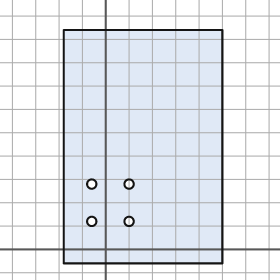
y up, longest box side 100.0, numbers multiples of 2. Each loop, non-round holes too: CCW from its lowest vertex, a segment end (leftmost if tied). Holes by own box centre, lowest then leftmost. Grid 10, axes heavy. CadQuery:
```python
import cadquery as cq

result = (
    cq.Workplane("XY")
    .moveTo(-18.0, -6.0)
    .lineTo(50.0, -6.0)
    .lineTo(50.0, 94.0)
    .lineTo(-18.0, 94.0)
    .close()
    .moveTo(-6.0, 12.0)
    .circle(2.0)
    .moveTo(10.0, 12.0)
    .circle(2.0)
    .moveTo(-6.0, 28.0)
    .circle(2.0)
    .moveTo(10.0, 28.0)
    .circle(2.0)
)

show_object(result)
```